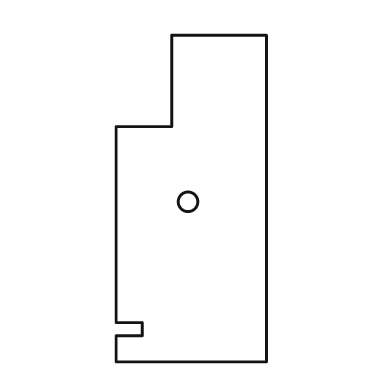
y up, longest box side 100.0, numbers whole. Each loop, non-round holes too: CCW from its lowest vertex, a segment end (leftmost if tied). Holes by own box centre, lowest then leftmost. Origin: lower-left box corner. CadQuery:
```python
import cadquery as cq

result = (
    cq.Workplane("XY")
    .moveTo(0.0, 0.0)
    .lineTo(46.0, 0.0)
    .lineTo(46.0, 100.0)
    .lineTo(17.0, 100.0)
    .lineTo(17.0, 72.0)
    .lineTo(0.0, 72.0)
    .lineTo(0.0, 12.0)
    .lineTo(8.0, 12.0)
    .lineTo(8.0, 8.0)
    .lineTo(0.0, 8.0)
    .close()
    .moveTo(22.0, 49.0)
    .circle(3.0)
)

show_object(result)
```